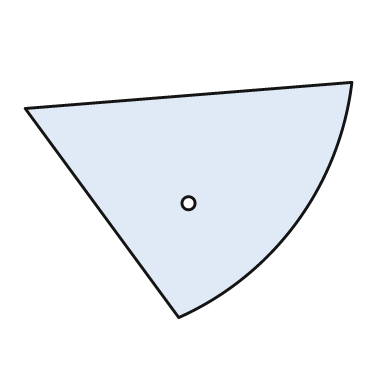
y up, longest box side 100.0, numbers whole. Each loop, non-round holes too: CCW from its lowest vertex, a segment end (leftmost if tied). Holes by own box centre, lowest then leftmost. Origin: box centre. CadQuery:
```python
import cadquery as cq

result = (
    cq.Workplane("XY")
    .moveTo(-3.0, -36.0)
    .threePointArc((33.0, -7.0), (50.0, 36.0))
    .lineTo(-50.0, 28.0)
    .close()
    .moveTo(0.0, -1.0)
    .circle(2.0)
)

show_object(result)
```